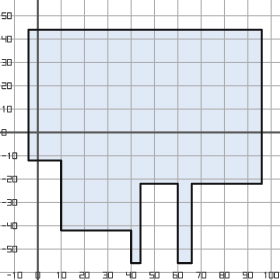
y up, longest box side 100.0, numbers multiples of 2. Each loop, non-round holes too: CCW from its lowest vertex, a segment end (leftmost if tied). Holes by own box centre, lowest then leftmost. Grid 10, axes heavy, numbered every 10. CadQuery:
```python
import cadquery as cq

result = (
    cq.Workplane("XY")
    .moveTo(40.0, -56.0)
    .lineTo(44.0, -56.0)
    .lineTo(44.0, -22.0)
    .lineTo(60.0, -22.0)
    .lineTo(60.0, -56.0)
    .lineTo(66.0, -56.0)
    .lineTo(66.0, -22.0)
    .lineTo(96.0, -22.0)
    .lineTo(96.0, 44.0)
    .lineTo(-4.0, 44.0)
    .lineTo(-4.0, -12.0)
    .lineTo(10.0, -12.0)
    .lineTo(10.0, -42.0)
    .lineTo(40.0, -42.0)
    .close()
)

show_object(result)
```